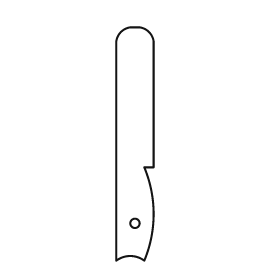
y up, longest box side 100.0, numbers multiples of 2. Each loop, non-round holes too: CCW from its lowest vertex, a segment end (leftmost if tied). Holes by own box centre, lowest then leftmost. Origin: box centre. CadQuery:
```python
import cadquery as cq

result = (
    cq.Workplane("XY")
    .moveTo(-8.0, -50.0)
    .threePointArc((-2.0, -48.0), (4.0, -50.0))
    .threePointArc((8.0, -30.0), (4.0, -10.0))
    .lineTo(8.0, -10.0)
    .lineTo(8.0, 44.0)
    .threePointArc((6.0, 48.0), (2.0, 50.0))
    .lineTo(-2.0, 50.0)
    .threePointArc((-6.0, 48.0), (-8.0, 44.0))
    .close()
    .moveTo(0.0, -34.0)
    .circle(2.0)
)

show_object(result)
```